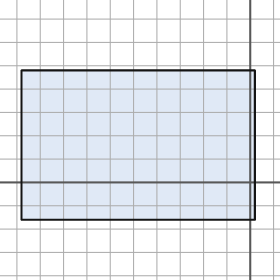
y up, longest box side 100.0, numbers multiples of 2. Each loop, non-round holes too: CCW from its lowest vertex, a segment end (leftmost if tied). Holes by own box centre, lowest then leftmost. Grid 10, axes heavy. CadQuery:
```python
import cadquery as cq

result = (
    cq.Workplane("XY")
    .moveTo(-98.0, -16.0)
    .lineTo(2.0, -16.0)
    .lineTo(2.0, 48.0)
    .lineTo(-98.0, 48.0)
    .close()
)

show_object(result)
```